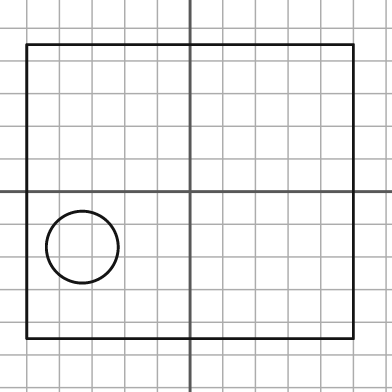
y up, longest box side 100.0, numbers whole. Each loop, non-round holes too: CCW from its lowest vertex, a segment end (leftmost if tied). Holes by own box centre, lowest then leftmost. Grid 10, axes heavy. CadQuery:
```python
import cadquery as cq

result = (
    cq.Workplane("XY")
    .moveTo(-50.0, -45.0)
    .lineTo(50.0, -45.0)
    .lineTo(50.0, 45.0)
    .lineTo(-50.0, 45.0)
    .close()
    .moveTo(-33.0, -17.0)
    .circle(11.0)
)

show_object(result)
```